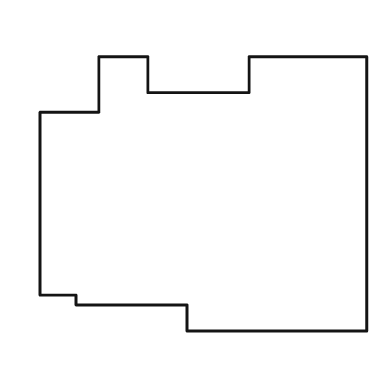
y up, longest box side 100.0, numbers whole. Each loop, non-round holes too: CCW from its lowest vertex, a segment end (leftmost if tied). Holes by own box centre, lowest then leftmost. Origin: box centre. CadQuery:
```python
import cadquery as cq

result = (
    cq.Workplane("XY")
    .moveTo(-5.0, -42.0)
    .lineTo(50.0, -42.0)
    .lineTo(50.0, 42.0)
    .lineTo(14.0, 42.0)
    .lineTo(14.0, 31.0)
    .lineTo(-17.0, 31.0)
    .lineTo(-17.0, 42.0)
    .lineTo(-32.0, 42.0)
    .lineTo(-32.0, 25.0)
    .lineTo(-50.0, 25.0)
    .lineTo(-50.0, -31.0)
    .lineTo(-39.0, -31.0)
    .lineTo(-39.0, -34.0)
    .lineTo(-5.0, -34.0)
    .close()
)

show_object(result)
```